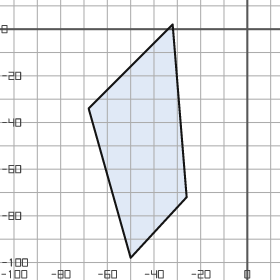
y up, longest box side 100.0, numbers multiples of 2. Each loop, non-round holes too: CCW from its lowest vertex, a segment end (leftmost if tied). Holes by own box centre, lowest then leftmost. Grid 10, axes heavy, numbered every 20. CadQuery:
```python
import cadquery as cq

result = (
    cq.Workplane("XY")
    .moveTo(-50.0, -98.0)
    .lineTo(-26.0, -72.0)
    .lineTo(-32.0, 2.0)
    .lineTo(-68.0, -34.0)
    .close()
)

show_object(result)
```